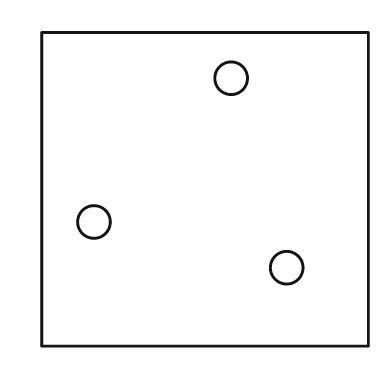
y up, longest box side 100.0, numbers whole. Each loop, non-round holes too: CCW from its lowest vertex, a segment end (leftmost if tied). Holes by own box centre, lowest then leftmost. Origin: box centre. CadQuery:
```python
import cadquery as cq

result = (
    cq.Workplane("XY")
    .moveTo(-50.0, -48.0)
    .lineTo(50.0, -48.0)
    .lineTo(50.0, 48.0)
    .lineTo(-50.0, 48.0)
    .close()
    .moveTo(25.0, -24.0)
    .circle(5.0)
    .moveTo(-34.0, -10.0)
    .circle(5.0)
    .moveTo(8.0, 34.0)
    .circle(5.0)
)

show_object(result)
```